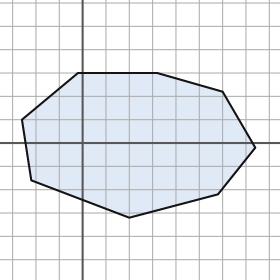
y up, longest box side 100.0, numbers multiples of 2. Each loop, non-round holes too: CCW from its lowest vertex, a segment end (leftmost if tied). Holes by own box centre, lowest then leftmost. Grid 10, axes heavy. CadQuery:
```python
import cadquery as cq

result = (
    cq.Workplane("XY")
    .moveTo(20.0, -32.0)
    .lineTo(58.0, -22.0)
    .lineTo(74.0, -2.0)
    .lineTo(60.0, 22.0)
    .lineTo(32.0, 30.0)
    .lineTo(-2.0, 30.0)
    .lineTo(-26.0, 10.0)
    .lineTo(-22.0, -16.0)
    .close()
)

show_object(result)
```